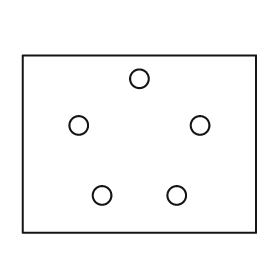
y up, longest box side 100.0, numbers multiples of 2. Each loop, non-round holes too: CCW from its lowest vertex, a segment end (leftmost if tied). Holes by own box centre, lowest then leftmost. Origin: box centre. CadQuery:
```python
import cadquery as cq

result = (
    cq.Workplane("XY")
    .moveTo(-50.0, -38.0)
    .lineTo(50.0, -38.0)
    .lineTo(50.0, 38.0)
    .lineTo(-50.0, 38.0)
    .close()
    .moveTo(-16.0, -22.0)
    .circle(4.0)
    .moveTo(16.0, -22.0)
    .circle(4.0)
    .moveTo(-26.0, 8.0)
    .circle(4.0)
    .moveTo(26.0, 8.0)
    .circle(4.0)
    .moveTo(0.0, 28.0)
    .circle(4.0)
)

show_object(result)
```